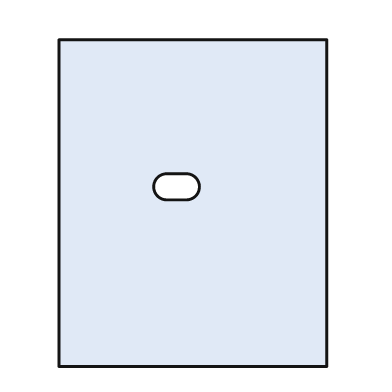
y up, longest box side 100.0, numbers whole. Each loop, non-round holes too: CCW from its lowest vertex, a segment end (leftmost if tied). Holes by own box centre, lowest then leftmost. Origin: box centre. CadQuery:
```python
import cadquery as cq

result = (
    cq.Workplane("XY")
    .moveTo(-41.0, -50.0)
    .lineTo(41.0, -50.0)
    .lineTo(41.0, 50.0)
    .lineTo(-41.0, 50.0)
    .close()
    .moveTo(-8.0, 1.0)
    .lineTo(-2.0, 1.0)
    .threePointArc((2.0, 5.0), (-2.0, 9.0))
    .lineTo(-8.0, 9.0)
    .threePointArc((-12.0, 5.0), (-8.0, 1.0))
    .close()
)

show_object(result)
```